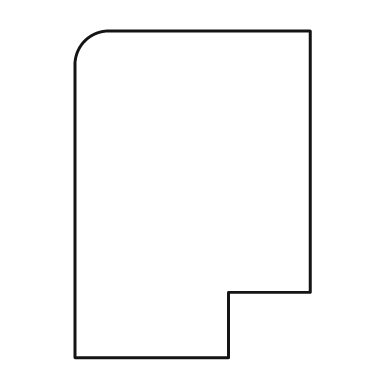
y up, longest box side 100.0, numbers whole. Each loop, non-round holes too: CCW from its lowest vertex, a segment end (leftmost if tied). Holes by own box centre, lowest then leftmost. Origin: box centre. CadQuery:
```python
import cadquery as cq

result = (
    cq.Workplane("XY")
    .moveTo(-36.0, -50.0)
    .lineTo(11.0, -50.0)
    .lineTo(11.0, -30.0)
    .lineTo(36.0, -30.0)
    .lineTo(36.0, 50.0)
    .lineTo(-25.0, 50.0)
    .threePointArc((-33.0, 47.0), (-36.0, 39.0))
    .close()
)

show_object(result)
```